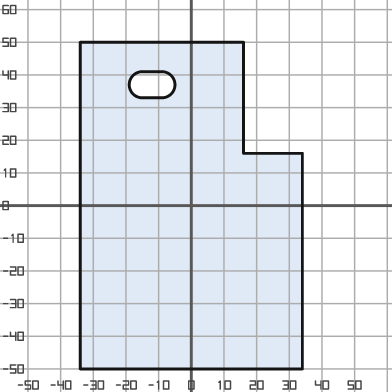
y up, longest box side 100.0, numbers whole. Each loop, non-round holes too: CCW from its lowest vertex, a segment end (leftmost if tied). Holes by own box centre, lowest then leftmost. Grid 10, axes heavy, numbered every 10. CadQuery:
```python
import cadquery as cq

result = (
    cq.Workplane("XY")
    .moveTo(-34.0, -50.0)
    .lineTo(34.0, -50.0)
    .lineTo(34.0, 16.0)
    .lineTo(16.0, 16.0)
    .lineTo(16.0, 50.0)
    .lineTo(-34.0, 50.0)
    .close()
    .moveTo(-15.0, 33.0)
    .lineTo(-9.0, 33.0)
    .threePointArc((-5.0, 37.0), (-9.0, 41.0))
    .lineTo(-15.0, 41.0)
    .threePointArc((-19.0, 37.0), (-15.0, 33.0))
    .close()
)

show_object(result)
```